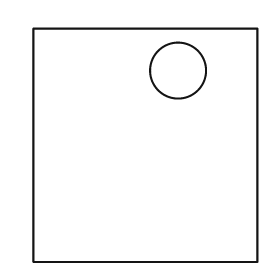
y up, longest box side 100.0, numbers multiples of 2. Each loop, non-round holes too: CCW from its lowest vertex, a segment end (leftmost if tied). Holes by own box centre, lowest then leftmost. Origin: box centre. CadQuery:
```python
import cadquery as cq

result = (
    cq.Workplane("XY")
    .moveTo(-48.0, -50.0)
    .lineTo(48.0, -50.0)
    .lineTo(48.0, 50.0)
    .lineTo(-48.0, 50.0)
    .close()
    .moveTo(14.0, 32.0)
    .circle(12.0)
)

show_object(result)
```